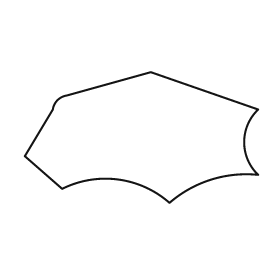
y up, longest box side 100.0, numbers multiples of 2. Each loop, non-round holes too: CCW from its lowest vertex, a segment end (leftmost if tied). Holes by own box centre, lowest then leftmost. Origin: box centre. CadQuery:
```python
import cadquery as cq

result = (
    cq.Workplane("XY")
    .moveTo(12.0, -28.0)
    .threePointArc((30.0, -18.0), (50.0, -16.0))
    .threePointArc((44.0, -2.0), (50.0, 12.0))
    .lineTo(4.0, 28.0)
    .lineTo(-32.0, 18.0)
    .threePointArc((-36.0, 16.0), (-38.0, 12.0))
    .lineTo(-50.0, -8.0)
    .lineTo(-34.0, -22.0)
    .threePointArc((-10.0, -18.0), (12.0, -28.0))
    .close()
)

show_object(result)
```